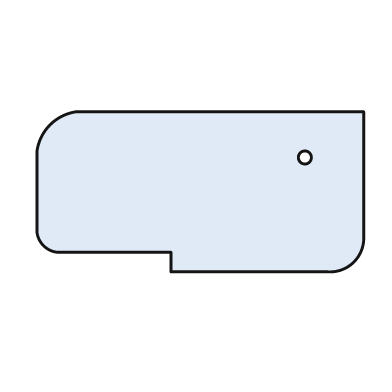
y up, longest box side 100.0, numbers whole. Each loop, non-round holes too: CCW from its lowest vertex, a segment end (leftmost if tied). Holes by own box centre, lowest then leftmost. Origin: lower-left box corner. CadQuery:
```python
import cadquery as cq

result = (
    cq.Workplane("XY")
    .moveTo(41.0, 0.0)
    .lineTo(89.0, 0.0)
    .threePointArc((97.0, 3.0), (100.0, 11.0))
    .lineTo(100.0, 49.0)
    .lineTo(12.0, 49.0)
    .threePointArc((4.0, 45.0), (0.0, 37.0))
    .lineTo(0.0, 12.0)
    .threePointArc((2.0, 8.0), (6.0, 6.0))
    .lineTo(41.0, 6.0)
    .close()
    .moveTo(82.0, 35.0)
    .circle(2.0)
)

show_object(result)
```